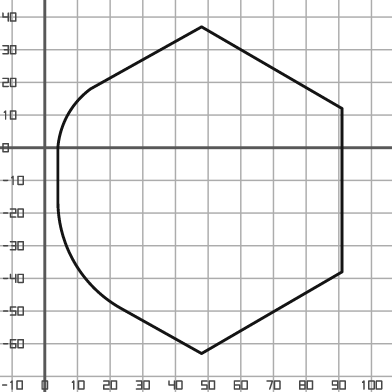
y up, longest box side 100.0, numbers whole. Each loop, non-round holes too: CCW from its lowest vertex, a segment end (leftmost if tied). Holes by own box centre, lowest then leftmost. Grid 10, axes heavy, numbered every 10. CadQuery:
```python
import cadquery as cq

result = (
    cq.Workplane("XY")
    .moveTo(48.0, -63.0)
    .lineTo(91.0, -38.0)
    .lineTo(91.0, 12.0)
    .lineTo(48.0, 37.0)
    .lineTo(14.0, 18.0)
    .threePointArc((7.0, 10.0), (4.0, 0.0))
    .lineTo(4.0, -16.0)
    .threePointArc((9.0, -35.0), (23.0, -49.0))
    .close()
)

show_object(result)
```